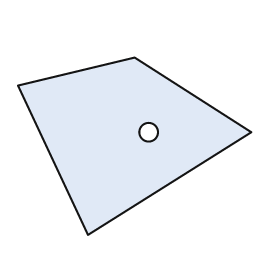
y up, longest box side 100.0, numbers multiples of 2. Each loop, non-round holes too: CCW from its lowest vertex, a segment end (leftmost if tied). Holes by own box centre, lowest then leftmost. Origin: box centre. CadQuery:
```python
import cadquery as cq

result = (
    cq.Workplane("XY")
    .moveTo(-20.0, -38.0)
    .lineTo(50.0, 6.0)
    .lineTo(0.0, 38.0)
    .lineTo(-50.0, 26.0)
    .close()
    .moveTo(6.0, 6.0)
    .circle(4.0)
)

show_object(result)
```